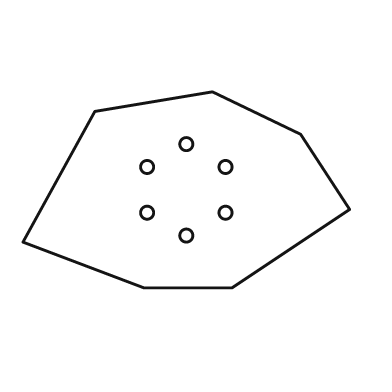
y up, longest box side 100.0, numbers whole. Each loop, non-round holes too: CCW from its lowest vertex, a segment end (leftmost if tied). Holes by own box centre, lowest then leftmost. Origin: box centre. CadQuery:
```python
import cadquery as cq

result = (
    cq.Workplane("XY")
    .moveTo(-13.0, -30.0)
    .lineTo(14.0, -30.0)
    .lineTo(50.0, -6.0)
    .lineTo(35.0, 17.0)
    .lineTo(8.0, 30.0)
    .lineTo(-28.0, 24.0)
    .lineTo(-50.0, -16.0)
    .close()
    .moveTo(0.0, -14.0)
    .circle(2.0)
    .moveTo(-12.0, -7.0)
    .circle(2.0)
    .moveTo(12.0, -7.0)
    .circle(2.0)
    .moveTo(-12.0, 7.0)
    .circle(2.0)
    .moveTo(12.0, 7.0)
    .circle(2.0)
    .moveTo(0.0, 14.0)
    .circle(2.0)
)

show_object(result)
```